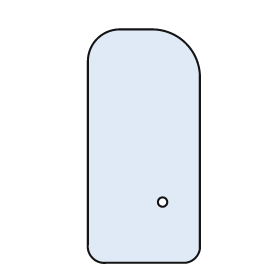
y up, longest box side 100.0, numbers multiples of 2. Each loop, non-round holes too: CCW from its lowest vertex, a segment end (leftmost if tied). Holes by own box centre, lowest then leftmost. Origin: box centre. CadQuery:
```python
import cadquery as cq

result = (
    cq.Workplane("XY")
    .moveTo(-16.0, -50.0)
    .lineTo(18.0, -50.0)
    .threePointArc((22.0, -48.0), (24.0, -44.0))
    .lineTo(24.0, 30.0)
    .threePointArc((18.0, 44.0), (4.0, 50.0))
    .lineTo(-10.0, 50.0)
    .threePointArc((-20.0, 46.0), (-24.0, 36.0))
    .lineTo(-24.0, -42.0)
    .threePointArc((-22.0, -48.0), (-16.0, -50.0))
    .close()
    .moveTo(8.0, -24.0)
    .circle(2.0)
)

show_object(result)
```